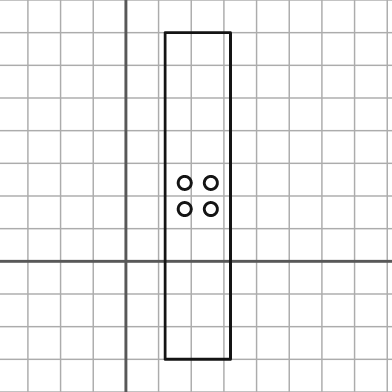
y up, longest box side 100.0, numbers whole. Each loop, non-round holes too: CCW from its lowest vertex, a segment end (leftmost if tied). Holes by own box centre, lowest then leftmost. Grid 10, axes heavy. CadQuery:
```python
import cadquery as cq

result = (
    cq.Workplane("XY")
    .moveTo(12.0, -30.0)
    .lineTo(32.0, -30.0)
    .lineTo(32.0, 70.0)
    .lineTo(12.0, 70.0)
    .close()
    .moveTo(18.0, 16.0)
    .circle(2.0)
    .moveTo(26.0, 16.0)
    .circle(2.0)
    .moveTo(18.0, 24.0)
    .circle(2.0)
    .moveTo(26.0, 24.0)
    .circle(2.0)
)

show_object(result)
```